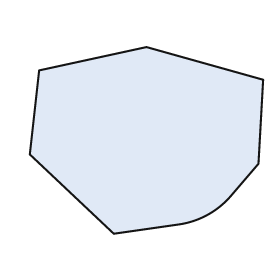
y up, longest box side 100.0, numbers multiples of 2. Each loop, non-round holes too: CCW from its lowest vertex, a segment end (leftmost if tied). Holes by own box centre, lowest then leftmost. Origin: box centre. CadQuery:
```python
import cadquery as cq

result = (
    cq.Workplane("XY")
    .moveTo(-14.0, -40.0)
    .lineTo(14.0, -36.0)
    .threePointArc((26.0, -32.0), (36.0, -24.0))
    .lineTo(48.0, -10.0)
    .lineTo(50.0, 26.0)
    .lineTo(0.0, 40.0)
    .lineTo(-46.0, 30.0)
    .lineTo(-50.0, -6.0)
    .close()
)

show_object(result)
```